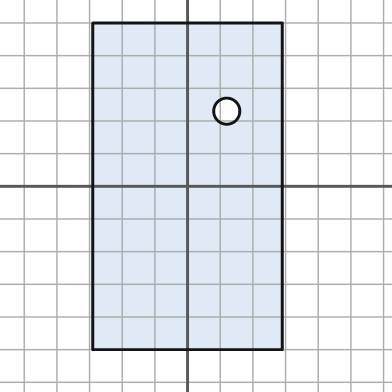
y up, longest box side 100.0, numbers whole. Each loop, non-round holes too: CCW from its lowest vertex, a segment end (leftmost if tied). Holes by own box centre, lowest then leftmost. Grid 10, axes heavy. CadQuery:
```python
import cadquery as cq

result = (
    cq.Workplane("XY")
    .moveTo(-29.0, -50.0)
    .lineTo(29.0, -50.0)
    .lineTo(29.0, 50.0)
    .lineTo(-29.0, 50.0)
    .close()
    .moveTo(12.0, 23.0)
    .circle(4.0)
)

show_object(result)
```